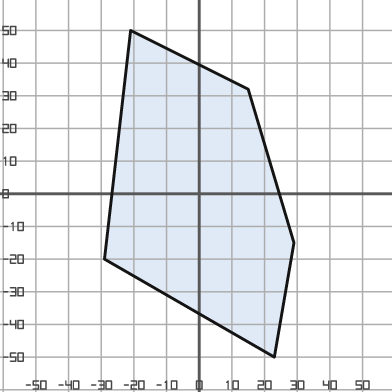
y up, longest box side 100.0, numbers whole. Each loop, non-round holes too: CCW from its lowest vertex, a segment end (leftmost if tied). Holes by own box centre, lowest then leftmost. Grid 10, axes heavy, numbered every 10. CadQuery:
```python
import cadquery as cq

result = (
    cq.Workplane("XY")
    .moveTo(23.0, -50.0)
    .lineTo(29.0, -15.0)
    .lineTo(15.0, 32.0)
    .lineTo(-21.0, 50.0)
    .lineTo(-29.0, -20.0)
    .close()
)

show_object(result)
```